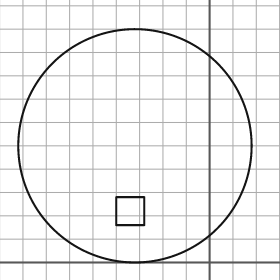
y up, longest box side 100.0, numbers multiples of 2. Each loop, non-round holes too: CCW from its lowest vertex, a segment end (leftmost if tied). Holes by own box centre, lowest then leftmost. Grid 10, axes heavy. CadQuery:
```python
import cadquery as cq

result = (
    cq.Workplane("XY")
    .moveTo(-32.0, 50.0)
    .circle(50.0)
    .moveTo(-40.0, 16.0)
    .lineTo(-28.0, 16.0)
    .lineTo(-28.0, 28.0)
    .lineTo(-40.0, 28.0)
    .close()
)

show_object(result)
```